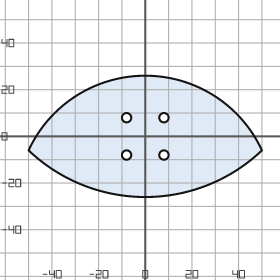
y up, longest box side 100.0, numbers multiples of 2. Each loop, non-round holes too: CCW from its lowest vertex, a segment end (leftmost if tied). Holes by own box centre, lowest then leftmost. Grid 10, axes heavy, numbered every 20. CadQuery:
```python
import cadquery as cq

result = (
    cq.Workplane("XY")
    .moveTo(-50.0, -6.0)
    .threePointArc((0.0, -26.0), (50.0, -6.0))
    .threePointArc((0.0, 26.0), (-50.0, -6.0))
    .close()
    .moveTo(-8.0, -8.0)
    .circle(2.0)
    .moveTo(8.0, -8.0)
    .circle(2.0)
    .moveTo(-8.0, 8.0)
    .circle(2.0)
    .moveTo(8.0, 8.0)
    .circle(2.0)
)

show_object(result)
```